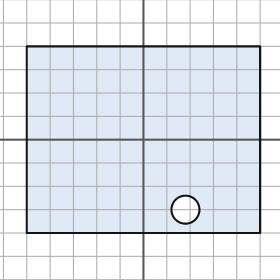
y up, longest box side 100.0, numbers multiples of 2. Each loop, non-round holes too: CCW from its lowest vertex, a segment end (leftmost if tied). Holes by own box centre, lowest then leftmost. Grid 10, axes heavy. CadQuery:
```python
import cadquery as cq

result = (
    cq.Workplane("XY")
    .moveTo(-50.0, -40.0)
    .lineTo(50.0, -40.0)
    .lineTo(50.0, 40.0)
    .lineTo(-50.0, 40.0)
    .close()
    .moveTo(18.0, -30.0)
    .circle(6.0)
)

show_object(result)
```